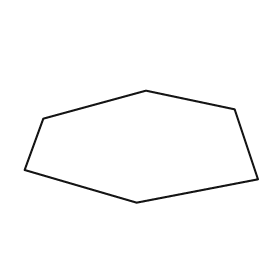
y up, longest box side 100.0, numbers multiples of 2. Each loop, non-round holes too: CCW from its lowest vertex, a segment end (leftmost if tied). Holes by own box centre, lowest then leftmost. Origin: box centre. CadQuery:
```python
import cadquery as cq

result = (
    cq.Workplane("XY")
    .moveTo(-2.0, -24.0)
    .lineTo(50.0, -14.0)
    .lineTo(40.0, 16.0)
    .lineTo(2.0, 24.0)
    .lineTo(-42.0, 12.0)
    .lineTo(-50.0, -10.0)
    .close()
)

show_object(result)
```